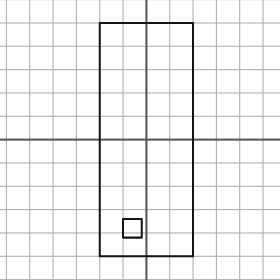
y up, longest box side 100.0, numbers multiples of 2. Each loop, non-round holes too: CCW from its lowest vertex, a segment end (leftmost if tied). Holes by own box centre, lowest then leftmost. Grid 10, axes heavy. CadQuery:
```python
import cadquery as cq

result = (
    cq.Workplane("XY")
    .moveTo(-20.0, -50.0)
    .lineTo(20.0, -50.0)
    .lineTo(20.0, 50.0)
    .lineTo(-20.0, 50.0)
    .close()
    .moveTo(-10.0, -42.0)
    .lineTo(-2.0, -42.0)
    .lineTo(-2.0, -34.0)
    .lineTo(-10.0, -34.0)
    .close()
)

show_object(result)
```